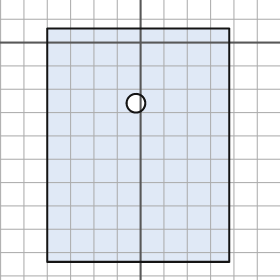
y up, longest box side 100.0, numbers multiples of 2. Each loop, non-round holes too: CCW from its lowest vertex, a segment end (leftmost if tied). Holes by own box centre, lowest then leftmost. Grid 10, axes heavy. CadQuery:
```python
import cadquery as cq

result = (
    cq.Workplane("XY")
    .moveTo(-40.0, -94.0)
    .lineTo(38.0, -94.0)
    .lineTo(38.0, 6.0)
    .lineTo(-40.0, 6.0)
    .close()
    .moveTo(-2.0, -26.0)
    .circle(4.0)
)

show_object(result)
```